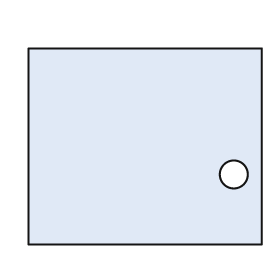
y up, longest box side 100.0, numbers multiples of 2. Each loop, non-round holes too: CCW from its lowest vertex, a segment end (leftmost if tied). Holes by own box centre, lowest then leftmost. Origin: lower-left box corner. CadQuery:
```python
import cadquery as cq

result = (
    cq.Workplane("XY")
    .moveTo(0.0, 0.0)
    .lineTo(100.0, 0.0)
    .lineTo(100.0, 84.0)
    .lineTo(0.0, 84.0)
    .close()
    .moveTo(88.0, 30.0)
    .circle(6.0)
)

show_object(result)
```